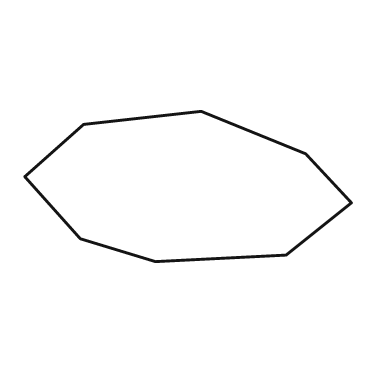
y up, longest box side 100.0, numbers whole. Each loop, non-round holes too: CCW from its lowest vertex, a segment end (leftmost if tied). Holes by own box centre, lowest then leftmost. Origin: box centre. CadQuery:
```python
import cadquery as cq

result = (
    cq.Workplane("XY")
    .moveTo(-10.0, -23.0)
    .lineTo(30.0, -21.0)
    .lineTo(50.0, -5.0)
    .lineTo(36.0, 10.0)
    .lineTo(4.0, 23.0)
    .lineTo(-32.0, 19.0)
    .lineTo(-50.0, 3.0)
    .lineTo(-33.0, -16.0)
    .close()
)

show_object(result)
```